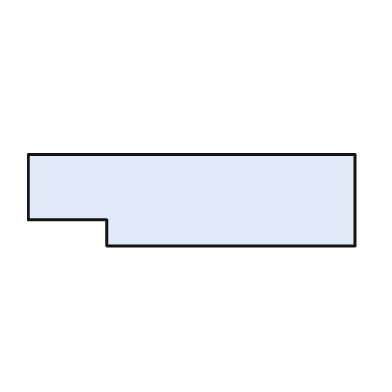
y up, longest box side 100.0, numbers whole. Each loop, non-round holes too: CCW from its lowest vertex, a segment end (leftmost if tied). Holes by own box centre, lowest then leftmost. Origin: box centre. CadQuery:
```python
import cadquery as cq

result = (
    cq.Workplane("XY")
    .moveTo(-26.0, -14.0)
    .lineTo(50.0, -14.0)
    .lineTo(50.0, 14.0)
    .lineTo(-50.0, 14.0)
    .lineTo(-50.0, -6.0)
    .lineTo(-26.0, -6.0)
    .close()
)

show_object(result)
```